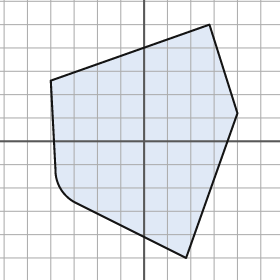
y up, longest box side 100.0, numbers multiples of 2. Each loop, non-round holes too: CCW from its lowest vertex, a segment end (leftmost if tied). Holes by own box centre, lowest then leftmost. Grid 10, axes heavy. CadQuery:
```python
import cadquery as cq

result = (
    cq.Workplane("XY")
    .moveTo(18.0, -50.0)
    .lineTo(40.0, 12.0)
    .lineTo(28.0, 50.0)
    .lineTo(-40.0, 26.0)
    .lineTo(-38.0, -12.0)
    .threePointArc((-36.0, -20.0), (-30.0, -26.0))
    .close()
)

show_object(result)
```